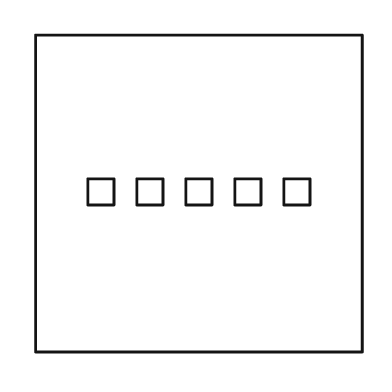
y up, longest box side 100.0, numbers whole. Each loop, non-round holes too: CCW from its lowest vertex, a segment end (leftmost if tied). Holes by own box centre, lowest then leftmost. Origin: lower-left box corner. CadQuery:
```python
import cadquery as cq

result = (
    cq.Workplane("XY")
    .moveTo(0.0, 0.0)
    .lineTo(100.0, 0.0)
    .lineTo(100.0, 97.0)
    .lineTo(0.0, 97.0)
    .close()
    .moveTo(16.0, 45.0)
    .lineTo(24.0, 45.0)
    .lineTo(24.0, 53.0)
    .lineTo(16.0, 53.0)
    .close()
    .moveTo(31.0, 45.0)
    .lineTo(39.0, 45.0)
    .lineTo(39.0, 53.0)
    .lineTo(31.0, 53.0)
    .close()
    .moveTo(46.0, 45.0)
    .lineTo(54.0, 45.0)
    .lineTo(54.0, 53.0)
    .lineTo(46.0, 53.0)
    .close()
    .moveTo(61.0, 45.0)
    .lineTo(69.0, 45.0)
    .lineTo(69.0, 53.0)
    .lineTo(61.0, 53.0)
    .close()
    .moveTo(76.0, 45.0)
    .lineTo(84.0, 45.0)
    .lineTo(84.0, 53.0)
    .lineTo(76.0, 53.0)
    .close()
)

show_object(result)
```